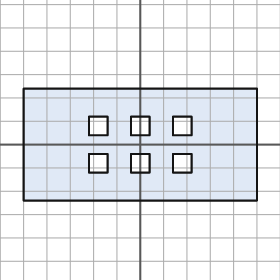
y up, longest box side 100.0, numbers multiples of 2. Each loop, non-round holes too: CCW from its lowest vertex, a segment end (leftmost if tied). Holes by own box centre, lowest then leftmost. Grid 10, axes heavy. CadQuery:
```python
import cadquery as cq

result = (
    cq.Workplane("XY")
    .moveTo(-50.0, -24.0)
    .lineTo(50.0, -24.0)
    .lineTo(50.0, 24.0)
    .lineTo(-50.0, 24.0)
    .close()
    .moveTo(-22.0, -12.0)
    .lineTo(-14.0, -12.0)
    .lineTo(-14.0, -4.0)
    .lineTo(-22.0, -4.0)
    .close()
    .moveTo(-4.0, -12.0)
    .lineTo(4.0, -12.0)
    .lineTo(4.0, -4.0)
    .lineTo(-4.0, -4.0)
    .close()
    .moveTo(14.0, -12.0)
    .lineTo(22.0, -12.0)
    .lineTo(22.0, -4.0)
    .lineTo(14.0, -4.0)
    .close()
    .moveTo(-22.0, 4.0)
    .lineTo(-14.0, 4.0)
    .lineTo(-14.0, 12.0)
    .lineTo(-22.0, 12.0)
    .close()
    .moveTo(-4.0, 4.0)
    .lineTo(4.0, 4.0)
    .lineTo(4.0, 12.0)
    .lineTo(-4.0, 12.0)
    .close()
    .moveTo(14.0, 4.0)
    .lineTo(22.0, 4.0)
    .lineTo(22.0, 12.0)
    .lineTo(14.0, 12.0)
    .close()
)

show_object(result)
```